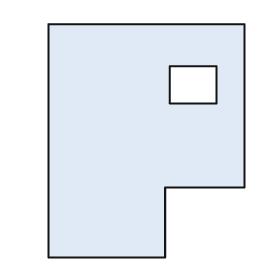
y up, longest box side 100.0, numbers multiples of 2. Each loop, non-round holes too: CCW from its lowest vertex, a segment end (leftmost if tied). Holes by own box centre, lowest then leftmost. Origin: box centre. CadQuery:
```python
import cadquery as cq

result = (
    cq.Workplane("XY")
    .moveTo(-42.0, -50.0)
    .lineTo(8.0, -50.0)
    .lineTo(8.0, -20.0)
    .lineTo(42.0, -20.0)
    .lineTo(42.0, 50.0)
    .lineTo(-42.0, 50.0)
    .close()
    .moveTo(10.0, 16.0)
    .lineTo(30.0, 16.0)
    .lineTo(30.0, 32.0)
    .lineTo(10.0, 32.0)
    .close()
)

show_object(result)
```